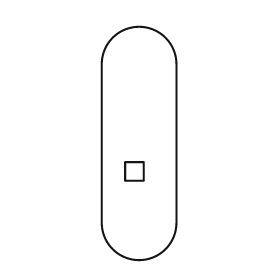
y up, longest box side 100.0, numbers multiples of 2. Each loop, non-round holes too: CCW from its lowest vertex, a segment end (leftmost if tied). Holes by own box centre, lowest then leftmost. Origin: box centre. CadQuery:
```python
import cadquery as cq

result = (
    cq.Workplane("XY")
    .moveTo(-16.0, -34.0)
    .threePointArc((0.0, -50.0), (16.0, -34.0))
    .lineTo(16.0, 34.0)
    .threePointArc((0.0, 50.0), (-16.0, 34.0))
    .close()
    .moveTo(-6.0, -16.0)
    .lineTo(2.0, -16.0)
    .lineTo(2.0, -8.0)
    .lineTo(-6.0, -8.0)
    .close()
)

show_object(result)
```